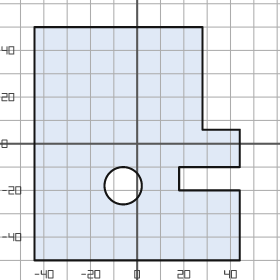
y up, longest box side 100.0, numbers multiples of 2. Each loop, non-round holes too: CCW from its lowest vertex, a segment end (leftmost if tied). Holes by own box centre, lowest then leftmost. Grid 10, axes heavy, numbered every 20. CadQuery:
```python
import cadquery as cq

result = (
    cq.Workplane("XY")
    .moveTo(-44.0, -50.0)
    .lineTo(44.0, -50.0)
    .lineTo(44.0, -20.0)
    .lineTo(18.0, -20.0)
    .lineTo(18.0, -10.0)
    .lineTo(44.0, -10.0)
    .lineTo(44.0, 6.0)
    .lineTo(28.0, 6.0)
    .lineTo(28.0, 50.0)
    .lineTo(-44.0, 50.0)
    .close()
    .moveTo(-6.0, -18.0)
    .circle(8.0)
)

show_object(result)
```